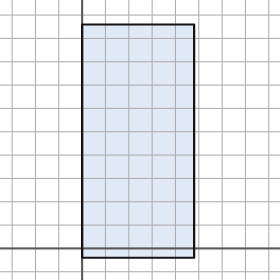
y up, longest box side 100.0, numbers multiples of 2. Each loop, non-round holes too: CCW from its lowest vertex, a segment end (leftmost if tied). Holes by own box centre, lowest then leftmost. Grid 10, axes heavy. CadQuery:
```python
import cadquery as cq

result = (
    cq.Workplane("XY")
    .moveTo(0.0, -4.0)
    .lineTo(48.0, -4.0)
    .lineTo(48.0, 96.0)
    .lineTo(0.0, 96.0)
    .close()
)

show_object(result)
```